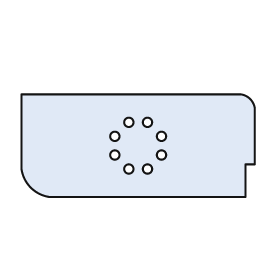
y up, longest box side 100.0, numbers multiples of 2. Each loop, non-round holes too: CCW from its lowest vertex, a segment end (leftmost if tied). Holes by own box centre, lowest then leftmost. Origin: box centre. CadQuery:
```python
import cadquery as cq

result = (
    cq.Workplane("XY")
    .moveTo(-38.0, -22.0)
    .lineTo(46.0, -22.0)
    .lineTo(46.0, -8.0)
    .lineTo(50.0, -8.0)
    .lineTo(50.0, 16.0)
    .threePointArc((48.0, 20.0), (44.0, 22.0))
    .lineTo(-50.0, 22.0)
    .lineTo(-50.0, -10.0)
    .threePointArc((-46.0, -18.0), (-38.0, -22.0))
    .close()
    .moveTo(-4.0, -10.0)
    .circle(2.0)
    .moveTo(4.0, -10.0)
    .circle(2.0)
    .moveTo(-10.0, -4.0)
    .circle(2.0)
    .moveTo(10.0, -4.0)
    .circle(2.0)
    .moveTo(-10.0, 4.0)
    .circle(2.0)
    .moveTo(10.0, 4.0)
    .circle(2.0)
    .moveTo(-4.0, 10.0)
    .circle(2.0)
    .moveTo(4.0, 10.0)
    .circle(2.0)
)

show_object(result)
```